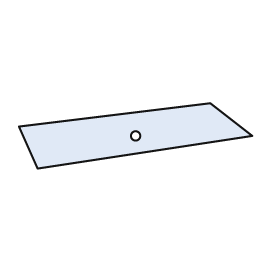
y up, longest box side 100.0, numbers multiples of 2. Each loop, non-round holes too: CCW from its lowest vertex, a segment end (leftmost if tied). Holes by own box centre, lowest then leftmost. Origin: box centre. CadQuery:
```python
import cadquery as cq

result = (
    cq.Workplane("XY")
    .moveTo(-42.0, -14.0)
    .lineTo(50.0, 0.0)
    .lineTo(32.0, 14.0)
    .lineTo(-50.0, 4.0)
    .close()
    .moveTo(0.0, 0.0)
    .circle(2.0)
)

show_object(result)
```